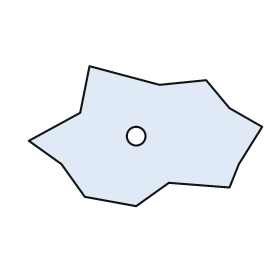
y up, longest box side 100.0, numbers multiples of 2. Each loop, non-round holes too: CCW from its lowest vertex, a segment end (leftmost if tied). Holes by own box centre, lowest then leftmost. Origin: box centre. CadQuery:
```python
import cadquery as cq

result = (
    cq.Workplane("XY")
    .moveTo(-4.0, -30.0)
    .lineTo(10.0, -20.0)
    .lineTo(36.0, -22.0)
    .lineTo(40.0, -12.0)
    .lineTo(50.0, 4.0)
    .lineTo(36.0, 12.0)
    .lineTo(26.0, 24.0)
    .lineTo(6.0, 22.0)
    .lineTo(-24.0, 30.0)
    .lineTo(-28.0, 10.0)
    .lineTo(-50.0, -2.0)
    .lineTo(-36.0, -12.0)
    .lineTo(-26.0, -26.0)
    .close()
    .moveTo(-4.0, 0.0)
    .circle(4.0)
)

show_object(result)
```